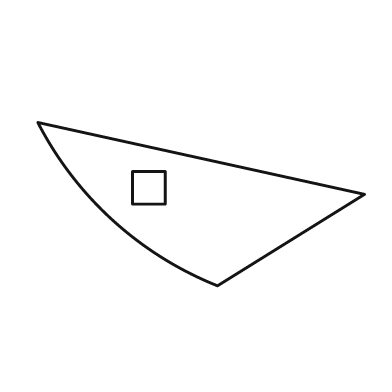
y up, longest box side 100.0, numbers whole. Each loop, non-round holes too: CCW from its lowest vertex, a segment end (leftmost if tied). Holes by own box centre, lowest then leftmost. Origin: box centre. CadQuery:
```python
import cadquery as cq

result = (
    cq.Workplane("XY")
    .moveTo(5.0, -25.0)
    .lineTo(50.0, 3.0)
    .lineTo(-50.0, 25.0)
    .threePointArc((-27.0, -5.0), (5.0, -25.0))
    .close()
    .moveTo(-21.0, 0.0)
    .lineTo(-11.0, 0.0)
    .lineTo(-11.0, 10.0)
    .lineTo(-21.0, 10.0)
    .close()
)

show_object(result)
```